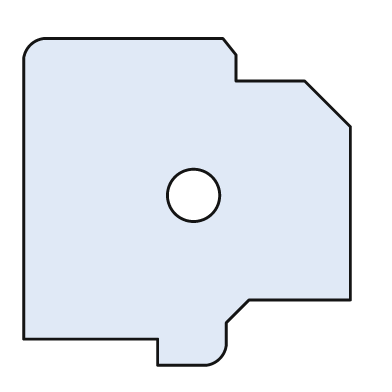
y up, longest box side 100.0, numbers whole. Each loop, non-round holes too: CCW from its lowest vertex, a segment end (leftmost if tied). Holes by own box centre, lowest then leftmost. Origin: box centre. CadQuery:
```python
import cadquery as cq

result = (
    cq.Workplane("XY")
    .moveTo(-9.0, -50.0)
    .lineTo(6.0, -50.0)
    .threePointArc((10.0, -48.0), (12.0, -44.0))
    .lineTo(12.0, -37.0)
    .lineTo(19.0, -30.0)
    .lineTo(50.0, -30.0)
    .lineTo(50.0, 23.0)
    .lineTo(36.0, 37.0)
    .lineTo(15.0, 37.0)
    .lineTo(15.0, 45.0)
    .lineTo(11.0, 50.0)
    .lineTo(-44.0, 50.0)
    .threePointArc((-48.0, 48.0), (-50.0, 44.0))
    .lineTo(-50.0, -42.0)
    .lineTo(-9.0, -42.0)
    .close()
    .moveTo(2.0, 2.0)
    .circle(8.0)
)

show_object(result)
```